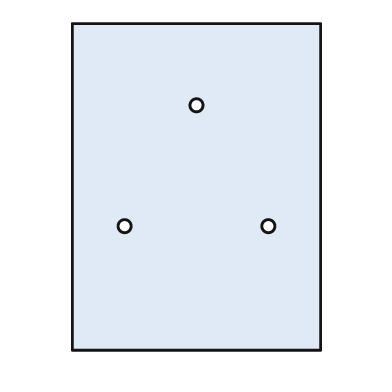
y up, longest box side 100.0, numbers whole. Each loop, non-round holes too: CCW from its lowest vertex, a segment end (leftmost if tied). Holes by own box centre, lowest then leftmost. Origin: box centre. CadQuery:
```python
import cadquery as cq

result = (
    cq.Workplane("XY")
    .moveTo(-38.0, -50.0)
    .lineTo(38.0, -50.0)
    .lineTo(38.0, 50.0)
    .lineTo(-38.0, 50.0)
    .close()
    .moveTo(-22.0, -12.0)
    .circle(2.0)
    .moveTo(22.0, -12.0)
    .circle(2.0)
    .moveTo(0.0, 25.0)
    .circle(2.0)
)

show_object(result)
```